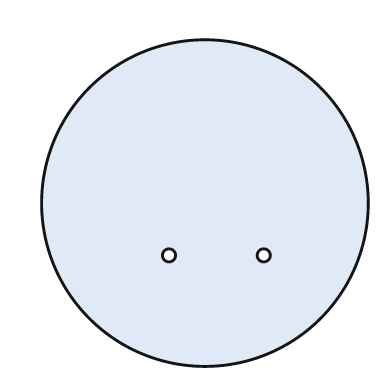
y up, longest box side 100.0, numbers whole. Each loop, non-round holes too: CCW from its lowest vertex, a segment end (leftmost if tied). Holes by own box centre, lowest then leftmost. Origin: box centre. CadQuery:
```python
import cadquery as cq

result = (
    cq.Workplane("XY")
    .moveTo(0.0, 0.0)
    .circle(50.0)
    .moveTo(-11.0, -16.0)
    .circle(2.0)
    .moveTo(18.0, -16.0)
    .circle(2.0)
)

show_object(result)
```